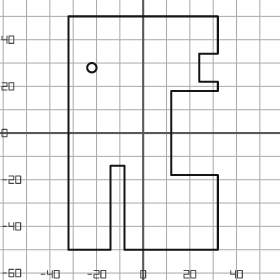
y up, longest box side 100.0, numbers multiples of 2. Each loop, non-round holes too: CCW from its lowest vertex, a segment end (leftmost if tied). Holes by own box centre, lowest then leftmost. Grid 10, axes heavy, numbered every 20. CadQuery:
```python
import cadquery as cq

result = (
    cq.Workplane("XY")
    .moveTo(-32.0, -50.0)
    .lineTo(-14.0, -50.0)
    .lineTo(-14.0, -14.0)
    .lineTo(-8.0, -14.0)
    .lineTo(-8.0, -50.0)
    .lineTo(32.0, -50.0)
    .lineTo(32.0, -18.0)
    .lineTo(12.0, -18.0)
    .lineTo(12.0, 18.0)
    .lineTo(32.0, 18.0)
    .lineTo(32.0, 22.0)
    .lineTo(24.0, 22.0)
    .lineTo(24.0, 34.0)
    .lineTo(32.0, 34.0)
    .lineTo(32.0, 50.0)
    .lineTo(-32.0, 50.0)
    .close()
    .moveTo(-22.0, 28.0)
    .circle(2.0)
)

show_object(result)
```